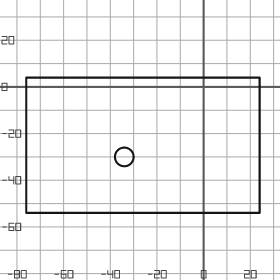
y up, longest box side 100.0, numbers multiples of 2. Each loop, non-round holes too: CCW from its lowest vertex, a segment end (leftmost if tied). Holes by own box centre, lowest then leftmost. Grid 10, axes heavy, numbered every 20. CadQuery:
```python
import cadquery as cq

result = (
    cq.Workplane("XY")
    .moveTo(-76.0, -54.0)
    .lineTo(24.0, -54.0)
    .lineTo(24.0, 4.0)
    .lineTo(-76.0, 4.0)
    .close()
    .moveTo(-34.0, -30.0)
    .circle(4.0)
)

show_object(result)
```